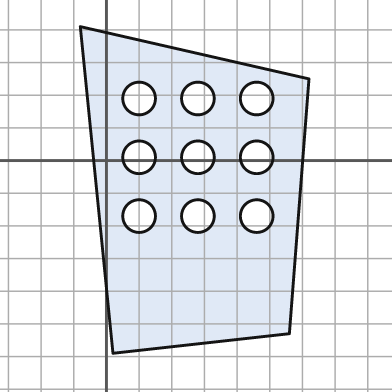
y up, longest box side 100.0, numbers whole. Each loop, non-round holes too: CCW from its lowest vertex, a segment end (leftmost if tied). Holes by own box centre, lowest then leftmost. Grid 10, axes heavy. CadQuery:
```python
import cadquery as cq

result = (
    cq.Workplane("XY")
    .moveTo(2.0, -59.0)
    .lineTo(56.0, -53.0)
    .lineTo(62.0, 25.0)
    .lineTo(-8.0, 41.0)
    .close()
    .moveTo(10.0, -17.0)
    .circle(5.0)
    .moveTo(28.0, -17.0)
    .circle(5.0)
    .moveTo(46.0, -17.0)
    .circle(5.0)
    .moveTo(10.0, 1.0)
    .circle(5.0)
    .moveTo(28.0, 1.0)
    .circle(5.0)
    .moveTo(46.0, 1.0)
    .circle(5.0)
    .moveTo(10.0, 19.0)
    .circle(5.0)
    .moveTo(28.0, 19.0)
    .circle(5.0)
    .moveTo(46.0, 19.0)
    .circle(5.0)
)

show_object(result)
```